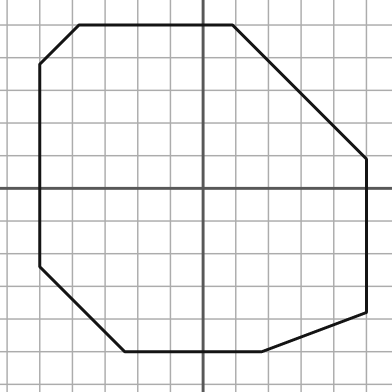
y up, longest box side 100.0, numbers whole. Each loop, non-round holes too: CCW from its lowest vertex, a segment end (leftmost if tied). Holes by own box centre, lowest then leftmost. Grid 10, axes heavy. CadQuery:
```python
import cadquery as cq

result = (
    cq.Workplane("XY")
    .moveTo(-24.0, -50.0)
    .lineTo(18.0, -50.0)
    .lineTo(50.0, -38.0)
    .lineTo(50.0, 9.0)
    .lineTo(9.0, 50.0)
    .lineTo(-38.0, 50.0)
    .lineTo(-50.0, 38.0)
    .lineTo(-50.0, -24.0)
    .close()
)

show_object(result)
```